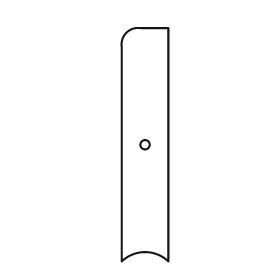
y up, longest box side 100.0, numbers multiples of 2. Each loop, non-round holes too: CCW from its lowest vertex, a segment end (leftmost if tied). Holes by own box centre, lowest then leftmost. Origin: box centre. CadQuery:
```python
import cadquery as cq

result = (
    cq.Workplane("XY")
    .moveTo(-10.0, -50.0)
    .threePointArc((0.0, -46.0), (10.0, -50.0))
    .lineTo(10.0, 50.0)
    .lineTo(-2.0, 50.0)
    .threePointArc((-8.0, 48.0), (-10.0, 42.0))
    .close()
    .moveTo(0.0, 0.0)
    .circle(2.0)
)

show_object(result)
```